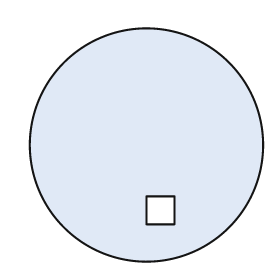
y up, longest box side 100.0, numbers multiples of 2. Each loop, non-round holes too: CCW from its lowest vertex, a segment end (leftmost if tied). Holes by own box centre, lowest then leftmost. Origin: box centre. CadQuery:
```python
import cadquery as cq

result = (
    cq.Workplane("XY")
    .moveTo(0.0, 0.0)
    .circle(50.0)
    .moveTo(0.0, -34.0)
    .lineTo(12.0, -34.0)
    .lineTo(12.0, -22.0)
    .lineTo(0.0, -22.0)
    .close()
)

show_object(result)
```